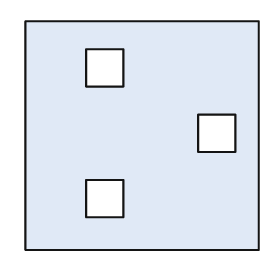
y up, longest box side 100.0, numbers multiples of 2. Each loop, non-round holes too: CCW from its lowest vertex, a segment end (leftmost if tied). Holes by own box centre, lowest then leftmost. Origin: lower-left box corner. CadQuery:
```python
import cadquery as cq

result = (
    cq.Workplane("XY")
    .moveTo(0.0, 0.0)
    .lineTo(100.0, 0.0)
    .lineTo(100.0, 98.0)
    .lineTo(0.0, 98.0)
    .close()
    .moveTo(26.0, 14.0)
    .lineTo(42.0, 14.0)
    .lineTo(42.0, 30.0)
    .lineTo(26.0, 30.0)
    .close()
    .moveTo(74.0, 42.0)
    .lineTo(90.0, 42.0)
    .lineTo(90.0, 58.0)
    .lineTo(74.0, 58.0)
    .close()
    .moveTo(26.0, 70.0)
    .lineTo(42.0, 70.0)
    .lineTo(42.0, 86.0)
    .lineTo(26.0, 86.0)
    .close()
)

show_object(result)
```